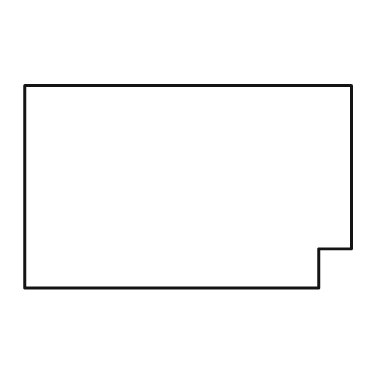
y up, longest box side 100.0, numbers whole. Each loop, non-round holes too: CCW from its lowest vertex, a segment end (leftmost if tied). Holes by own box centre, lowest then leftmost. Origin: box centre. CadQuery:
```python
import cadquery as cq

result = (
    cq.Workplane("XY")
    .moveTo(-50.0, -31.0)
    .lineTo(40.0, -31.0)
    .lineTo(40.0, -19.0)
    .lineTo(50.0, -19.0)
    .lineTo(50.0, 31.0)
    .lineTo(-50.0, 31.0)
    .close()
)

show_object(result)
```